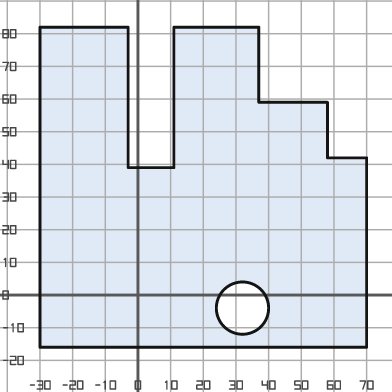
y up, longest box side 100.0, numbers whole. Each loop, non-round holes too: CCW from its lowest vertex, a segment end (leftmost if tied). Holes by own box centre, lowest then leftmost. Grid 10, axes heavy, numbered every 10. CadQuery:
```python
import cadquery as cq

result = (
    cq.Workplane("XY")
    .moveTo(-30.0, -16.0)
    .lineTo(70.0, -16.0)
    .lineTo(70.0, 42.0)
    .lineTo(58.0, 42.0)
    .lineTo(58.0, 59.0)
    .lineTo(37.0, 59.0)
    .lineTo(37.0, 82.0)
    .lineTo(11.0, 82.0)
    .lineTo(11.0, 39.0)
    .lineTo(-3.0, 39.0)
    .lineTo(-3.0, 82.0)
    .lineTo(-30.0, 82.0)
    .close()
    .moveTo(32.0, -4.0)
    .circle(8.0)
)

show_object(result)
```